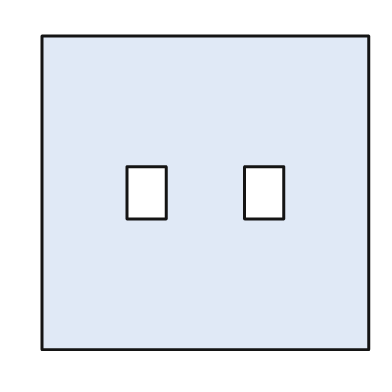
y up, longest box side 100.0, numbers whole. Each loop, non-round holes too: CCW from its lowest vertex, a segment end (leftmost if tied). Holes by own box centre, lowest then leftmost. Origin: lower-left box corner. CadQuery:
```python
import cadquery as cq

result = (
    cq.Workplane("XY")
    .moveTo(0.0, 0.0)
    .lineTo(100.0, 0.0)
    .lineTo(100.0, 96.0)
    .lineTo(0.0, 96.0)
    .close()
    .moveTo(26.0, 40.0)
    .lineTo(38.0, 40.0)
    .lineTo(38.0, 56.0)
    .lineTo(26.0, 56.0)
    .close()
    .moveTo(62.0, 40.0)
    .lineTo(74.0, 40.0)
    .lineTo(74.0, 56.0)
    .lineTo(62.0, 56.0)
    .close()
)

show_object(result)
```